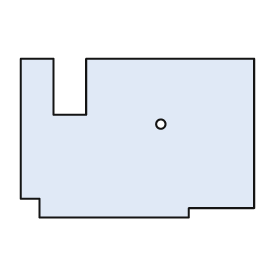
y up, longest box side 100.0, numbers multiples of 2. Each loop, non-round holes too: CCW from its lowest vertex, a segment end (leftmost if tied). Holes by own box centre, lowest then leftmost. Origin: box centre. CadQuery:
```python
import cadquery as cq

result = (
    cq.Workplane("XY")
    .moveTo(-42.0, -34.0)
    .lineTo(22.0, -34.0)
    .lineTo(22.0, -30.0)
    .lineTo(50.0, -30.0)
    .lineTo(50.0, 34.0)
    .lineTo(-22.0, 34.0)
    .lineTo(-22.0, 10.0)
    .lineTo(-36.0, 10.0)
    .lineTo(-36.0, 34.0)
    .lineTo(-50.0, 34.0)
    .lineTo(-50.0, -26.0)
    .lineTo(-42.0, -26.0)
    .close()
    .moveTo(10.0, 6.0)
    .circle(2.0)
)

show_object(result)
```